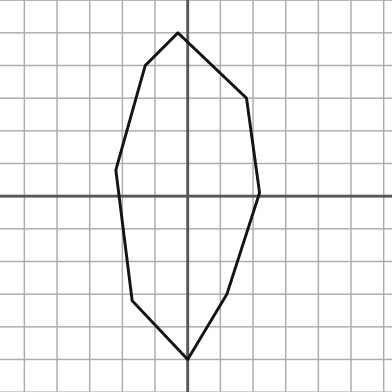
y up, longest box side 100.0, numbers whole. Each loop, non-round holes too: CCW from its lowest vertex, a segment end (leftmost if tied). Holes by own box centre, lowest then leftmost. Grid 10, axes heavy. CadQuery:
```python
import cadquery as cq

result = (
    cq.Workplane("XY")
    .moveTo(0.0, -50.0)
    .lineTo(12.0, -30.0)
    .lineTo(22.0, 1.0)
    .lineTo(18.0, 30.0)
    .lineTo(-3.0, 50.0)
    .lineTo(-13.0, 40.0)
    .lineTo(-22.0, 8.0)
    .lineTo(-17.0, -32.0)
    .close()
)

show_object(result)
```